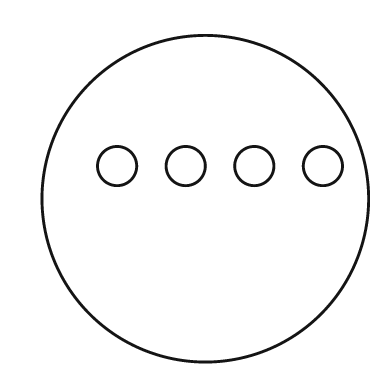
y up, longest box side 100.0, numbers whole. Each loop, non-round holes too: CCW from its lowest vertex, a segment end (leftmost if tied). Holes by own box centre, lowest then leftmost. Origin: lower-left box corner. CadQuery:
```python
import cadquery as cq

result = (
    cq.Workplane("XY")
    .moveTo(50.0, 50.0)
    .circle(50.0)
    .moveTo(23.0, 60.0)
    .circle(6.0)
    .moveTo(44.0, 60.0)
    .circle(6.0)
    .moveTo(65.0, 60.0)
    .circle(6.0)
    .moveTo(86.0, 60.0)
    .circle(6.0)
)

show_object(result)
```